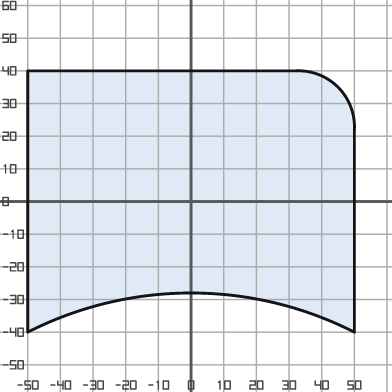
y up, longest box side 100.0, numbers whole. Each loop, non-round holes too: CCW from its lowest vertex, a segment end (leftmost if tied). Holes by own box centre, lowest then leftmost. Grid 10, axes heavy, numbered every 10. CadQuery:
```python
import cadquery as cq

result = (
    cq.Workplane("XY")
    .moveTo(-50.0, -40.0)
    .threePointArc((0.0, -28.0), (50.0, -40.0))
    .lineTo(50.0, 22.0)
    .threePointArc((45.0, 35.0), (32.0, 40.0))
    .lineTo(-50.0, 40.0)
    .close()
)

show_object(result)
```